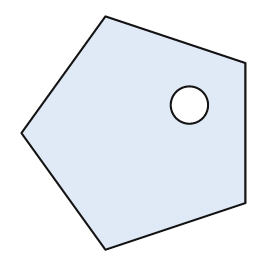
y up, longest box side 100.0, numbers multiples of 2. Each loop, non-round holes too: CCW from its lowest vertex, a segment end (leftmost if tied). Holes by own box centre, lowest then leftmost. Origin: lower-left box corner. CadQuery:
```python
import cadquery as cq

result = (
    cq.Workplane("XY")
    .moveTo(36.0, 0.0)
    .lineTo(96.0, 20.0)
    .lineTo(96.0, 80.0)
    .lineTo(36.0, 100.0)
    .lineTo(0.0, 50.0)
    .close()
    .moveTo(72.0, 62.0)
    .circle(8.0)
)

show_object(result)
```